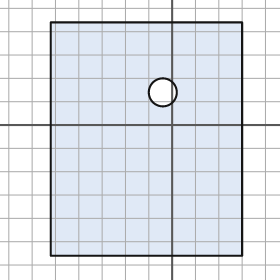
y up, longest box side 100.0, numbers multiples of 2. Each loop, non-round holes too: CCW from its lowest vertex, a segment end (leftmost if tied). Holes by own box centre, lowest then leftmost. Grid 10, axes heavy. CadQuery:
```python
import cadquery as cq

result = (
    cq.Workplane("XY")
    .moveTo(-52.0, -56.0)
    .lineTo(30.0, -56.0)
    .lineTo(30.0, 44.0)
    .lineTo(-52.0, 44.0)
    .close()
    .moveTo(-4.0, 14.0)
    .circle(6.0)
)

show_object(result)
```